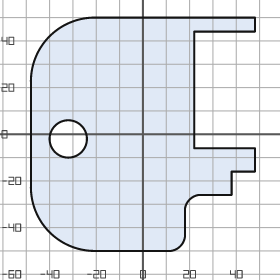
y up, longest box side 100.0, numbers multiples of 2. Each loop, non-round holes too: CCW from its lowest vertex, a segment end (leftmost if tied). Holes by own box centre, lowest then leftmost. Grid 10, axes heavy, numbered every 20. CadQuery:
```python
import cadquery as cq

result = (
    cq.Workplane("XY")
    .moveTo(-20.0, -50.0)
    .lineTo(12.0, -50.0)
    .threePointArc((16.0, -48.0), (18.0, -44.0))
    .lineTo(18.0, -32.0)
    .threePointArc((20.0, -28.0), (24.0, -26.0))
    .lineTo(38.0, -26.0)
    .lineTo(38.0, -16.0)
    .lineTo(48.0, -16.0)
    .lineTo(48.0, -6.0)
    .lineTo(22.0, -6.0)
    .lineTo(22.0, 44.0)
    .lineTo(48.0, 44.0)
    .lineTo(48.0, 50.0)
    .lineTo(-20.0, 50.0)
    .threePointArc((-40.0, 42.0), (-48.0, 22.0))
    .lineTo(-48.0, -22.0)
    .threePointArc((-40.0, -42.0), (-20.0, -50.0))
    .close()
    .moveTo(-32.0, -2.0)
    .circle(8.0)
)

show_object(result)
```